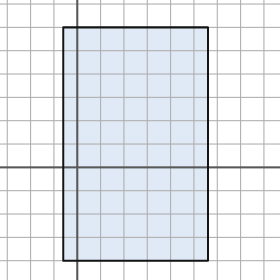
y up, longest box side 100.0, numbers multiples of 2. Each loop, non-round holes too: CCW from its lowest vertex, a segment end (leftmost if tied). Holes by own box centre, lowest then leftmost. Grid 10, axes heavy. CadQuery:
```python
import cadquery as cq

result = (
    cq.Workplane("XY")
    .moveTo(-6.0, -40.0)
    .lineTo(56.0, -40.0)
    .lineTo(56.0, 60.0)
    .lineTo(-6.0, 60.0)
    .close()
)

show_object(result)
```